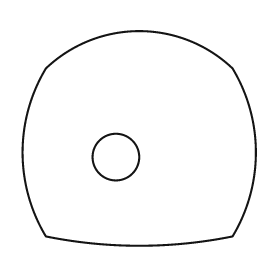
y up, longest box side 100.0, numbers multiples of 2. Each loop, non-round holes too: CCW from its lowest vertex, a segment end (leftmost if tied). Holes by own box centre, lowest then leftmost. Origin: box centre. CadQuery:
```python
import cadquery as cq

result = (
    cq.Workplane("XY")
    .moveTo(-40.0, -42.0)
    .threePointArc((0.0, -46.0), (40.0, -42.0))
    .threePointArc((50.0, -6.0), (40.0, 30.0))
    .threePointArc((0.0, 46.0), (-40.0, 30.0))
    .threePointArc((-50.0, -6.0), (-40.0, -42.0))
    .close()
    .moveTo(-10.0, -8.0)
    .circle(10.0)
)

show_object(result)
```